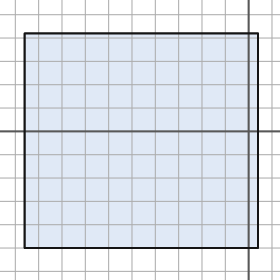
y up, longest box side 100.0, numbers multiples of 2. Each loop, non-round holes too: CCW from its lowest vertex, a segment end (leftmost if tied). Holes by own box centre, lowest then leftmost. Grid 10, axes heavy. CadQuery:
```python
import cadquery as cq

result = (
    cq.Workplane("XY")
    .moveTo(-96.0, -50.0)
    .lineTo(4.0, -50.0)
    .lineTo(4.0, 42.0)
    .lineTo(-96.0, 42.0)
    .close()
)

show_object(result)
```